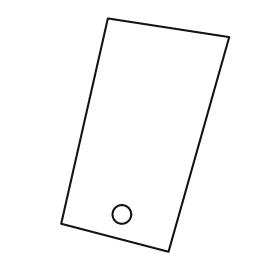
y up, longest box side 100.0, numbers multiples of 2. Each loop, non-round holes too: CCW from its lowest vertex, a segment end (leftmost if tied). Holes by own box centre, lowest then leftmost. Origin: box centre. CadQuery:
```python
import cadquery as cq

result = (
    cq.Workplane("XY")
    .moveTo(10.0, -50.0)
    .lineTo(36.0, 42.0)
    .lineTo(-16.0, 50.0)
    .lineTo(-36.0, -38.0)
    .close()
    .moveTo(-10.0, -34.0)
    .circle(4.0)
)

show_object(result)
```